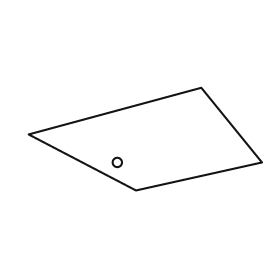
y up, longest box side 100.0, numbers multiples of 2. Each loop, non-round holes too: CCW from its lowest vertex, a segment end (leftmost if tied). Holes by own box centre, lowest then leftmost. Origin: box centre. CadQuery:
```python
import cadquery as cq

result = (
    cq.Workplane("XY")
    .moveTo(-4.0, -22.0)
    .lineTo(50.0, -10.0)
    .lineTo(24.0, 22.0)
    .lineTo(-50.0, 2.0)
    .close()
    .moveTo(-12.0, -10.0)
    .circle(2.0)
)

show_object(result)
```